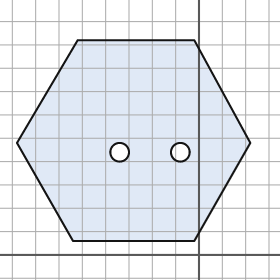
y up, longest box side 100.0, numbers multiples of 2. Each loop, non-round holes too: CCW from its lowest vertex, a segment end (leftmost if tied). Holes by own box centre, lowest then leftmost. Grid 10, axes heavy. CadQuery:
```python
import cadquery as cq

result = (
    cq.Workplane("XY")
    .moveTo(-54.0, 6.0)
    .lineTo(-2.0, 6.0)
    .lineTo(22.0, 48.0)
    .lineTo(-2.0, 92.0)
    .lineTo(-52.0, 92.0)
    .lineTo(-78.0, 48.0)
    .close()
    .moveTo(-34.0, 44.0)
    .circle(4.0)
    .moveTo(-8.0, 44.0)
    .circle(4.0)
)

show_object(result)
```